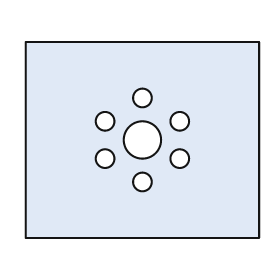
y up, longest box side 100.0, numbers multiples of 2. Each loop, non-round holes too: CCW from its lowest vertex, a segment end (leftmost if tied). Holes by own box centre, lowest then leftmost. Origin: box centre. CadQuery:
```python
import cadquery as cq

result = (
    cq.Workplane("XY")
    .moveTo(-50.0, -42.0)
    .lineTo(50.0, -42.0)
    .lineTo(50.0, 42.0)
    .lineTo(-50.0, 42.0)
    .close()
    .moveTo(0.0, -18.0)
    .circle(4.0)
    .moveTo(-16.0, -8.0)
    .circle(4.0)
    .moveTo(16.0, -8.0)
    .circle(4.0)
    .moveTo(0.0, 0.0)
    .circle(8.0)
    .moveTo(-16.0, 8.0)
    .circle(4.0)
    .moveTo(16.0, 8.0)
    .circle(4.0)
    .moveTo(0.0, 18.0)
    .circle(4.0)
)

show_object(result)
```